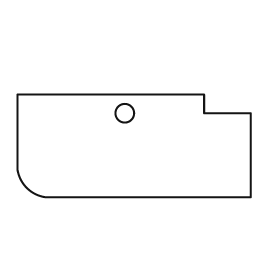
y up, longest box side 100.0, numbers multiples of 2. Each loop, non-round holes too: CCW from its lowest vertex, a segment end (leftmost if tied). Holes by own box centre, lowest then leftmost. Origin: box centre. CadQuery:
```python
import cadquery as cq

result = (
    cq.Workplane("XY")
    .moveTo(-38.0, -22.0)
    .lineTo(50.0, -22.0)
    .lineTo(50.0, 14.0)
    .lineTo(30.0, 14.0)
    .lineTo(30.0, 22.0)
    .lineTo(-50.0, 22.0)
    .lineTo(-50.0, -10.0)
    .threePointArc((-46.0, -18.0), (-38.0, -22.0))
    .close()
    .moveTo(-4.0, 14.0)
    .circle(4.0)
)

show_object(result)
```